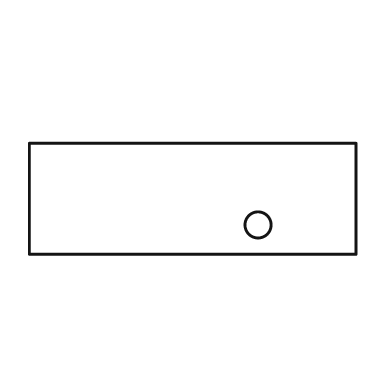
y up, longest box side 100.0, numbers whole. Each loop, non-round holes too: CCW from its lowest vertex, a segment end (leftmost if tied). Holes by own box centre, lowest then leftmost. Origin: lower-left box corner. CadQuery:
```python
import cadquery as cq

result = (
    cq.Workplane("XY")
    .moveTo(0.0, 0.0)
    .lineTo(100.0, 0.0)
    .lineTo(100.0, 34.0)
    .lineTo(0.0, 34.0)
    .close()
    .moveTo(70.0, 9.0)
    .circle(4.0)
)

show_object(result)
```